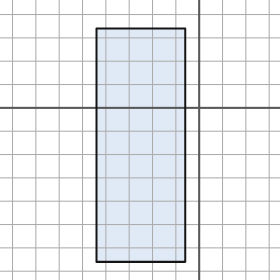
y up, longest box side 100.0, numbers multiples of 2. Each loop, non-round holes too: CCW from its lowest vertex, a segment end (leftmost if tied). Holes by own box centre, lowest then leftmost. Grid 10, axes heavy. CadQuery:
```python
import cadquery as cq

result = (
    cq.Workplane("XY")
    .moveTo(-44.0, -66.0)
    .lineTo(-6.0, -66.0)
    .lineTo(-6.0, 34.0)
    .lineTo(-44.0, 34.0)
    .close()
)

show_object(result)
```